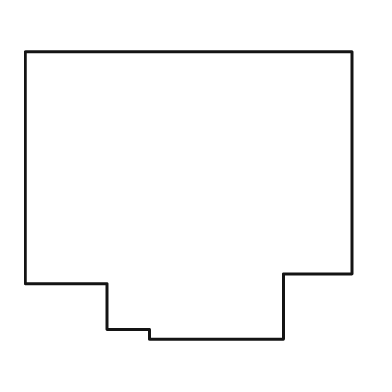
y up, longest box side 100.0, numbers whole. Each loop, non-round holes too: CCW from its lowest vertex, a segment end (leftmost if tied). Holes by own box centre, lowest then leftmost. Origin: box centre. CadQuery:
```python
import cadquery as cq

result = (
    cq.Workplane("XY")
    .moveTo(-12.0, -44.0)
    .lineTo(29.0, -44.0)
    .lineTo(29.0, -24.0)
    .lineTo(50.0, -24.0)
    .lineTo(50.0, 44.0)
    .lineTo(-50.0, 44.0)
    .lineTo(-50.0, -27.0)
    .lineTo(-25.0, -27.0)
    .lineTo(-25.0, -41.0)
    .lineTo(-12.0, -41.0)
    .close()
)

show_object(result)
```